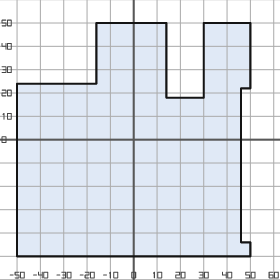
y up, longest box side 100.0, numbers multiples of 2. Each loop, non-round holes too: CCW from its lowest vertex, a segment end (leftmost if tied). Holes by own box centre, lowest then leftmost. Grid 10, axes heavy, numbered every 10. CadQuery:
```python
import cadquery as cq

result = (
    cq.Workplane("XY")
    .moveTo(-50.0, -50.0)
    .lineTo(50.0, -50.0)
    .lineTo(50.0, -44.0)
    .lineTo(46.0, -44.0)
    .lineTo(46.0, 22.0)
    .lineTo(50.0, 22.0)
    .lineTo(50.0, 50.0)
    .lineTo(30.0, 50.0)
    .lineTo(30.0, 18.0)
    .lineTo(14.0, 18.0)
    .lineTo(14.0, 50.0)
    .lineTo(-16.0, 50.0)
    .lineTo(-16.0, 24.0)
    .lineTo(-50.0, 24.0)
    .close()
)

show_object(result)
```